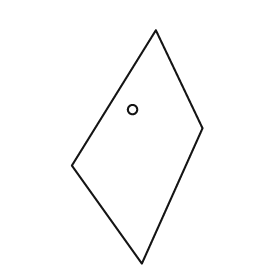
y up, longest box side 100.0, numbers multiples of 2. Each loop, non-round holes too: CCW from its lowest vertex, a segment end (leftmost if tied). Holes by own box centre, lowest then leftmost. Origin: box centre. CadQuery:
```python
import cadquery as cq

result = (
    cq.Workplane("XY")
    .moveTo(2.0, -50.0)
    .lineTo(28.0, 8.0)
    .lineTo(8.0, 50.0)
    .lineTo(-28.0, -8.0)
    .close()
    .moveTo(-2.0, 16.0)
    .circle(2.0)
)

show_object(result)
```